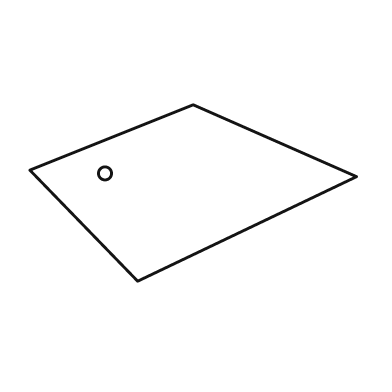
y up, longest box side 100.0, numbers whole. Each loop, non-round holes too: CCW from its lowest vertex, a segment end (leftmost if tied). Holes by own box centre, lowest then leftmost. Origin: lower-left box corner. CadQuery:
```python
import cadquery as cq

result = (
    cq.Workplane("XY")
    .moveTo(33.0, 0.0)
    .lineTo(100.0, 32.0)
    .lineTo(50.0, 54.0)
    .lineTo(0.0, 34.0)
    .close()
    .moveTo(23.0, 33.0)
    .circle(2.0)
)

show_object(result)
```